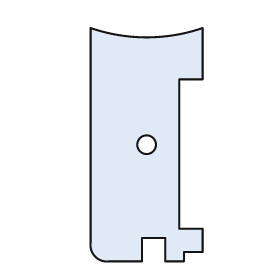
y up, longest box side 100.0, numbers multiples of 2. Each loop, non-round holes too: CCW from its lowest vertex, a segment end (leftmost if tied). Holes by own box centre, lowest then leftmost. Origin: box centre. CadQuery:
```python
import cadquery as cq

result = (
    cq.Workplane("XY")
    .moveTo(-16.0, -50.0)
    .lineTo(-2.0, -50.0)
    .lineTo(-2.0, -40.0)
    .lineTo(8.0, -40.0)
    .lineTo(8.0, -50.0)
    .lineTo(16.0, -50.0)
    .lineTo(16.0, -46.0)
    .lineTo(24.0, -46.0)
    .lineTo(24.0, -36.0)
    .lineTo(14.0, -36.0)
    .lineTo(14.0, 28.0)
    .lineTo(24.0, 28.0)
    .lineTo(24.0, 50.0)
    .threePointArc((0.0, 46.0), (-24.0, 50.0))
    .lineTo(-24.0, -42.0)
    .threePointArc((-22.0, -48.0), (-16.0, -50.0))
    .close()
    .moveTo(0.0, 0.0)
    .circle(4.0)
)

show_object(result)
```